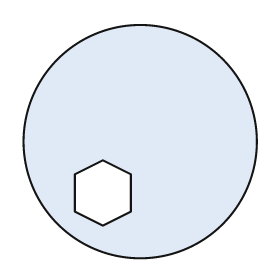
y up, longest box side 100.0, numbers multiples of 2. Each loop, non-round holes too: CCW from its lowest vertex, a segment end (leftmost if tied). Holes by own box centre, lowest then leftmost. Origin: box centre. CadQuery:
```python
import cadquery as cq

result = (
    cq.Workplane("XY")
    .moveTo(0.0, 0.0)
    .circle(50.0)
    .moveTo(-16.0, -36.0)
    .lineTo(-4.0, -30.0)
    .lineTo(-4.0, -14.0)
    .lineTo(-16.0, -8.0)
    .lineTo(-28.0, -14.0)
    .lineTo(-28.0, -30.0)
    .close()
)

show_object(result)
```